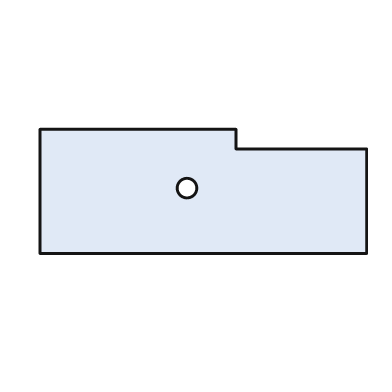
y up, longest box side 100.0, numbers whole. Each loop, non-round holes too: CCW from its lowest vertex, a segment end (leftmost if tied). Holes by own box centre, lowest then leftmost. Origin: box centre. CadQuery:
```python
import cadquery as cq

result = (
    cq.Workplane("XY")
    .moveTo(-50.0, -19.0)
    .lineTo(50.0, -19.0)
    .lineTo(50.0, 13.0)
    .lineTo(10.0, 13.0)
    .lineTo(10.0, 19.0)
    .lineTo(-50.0, 19.0)
    .close()
    .moveTo(-5.0, 1.0)
    .circle(3.0)
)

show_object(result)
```